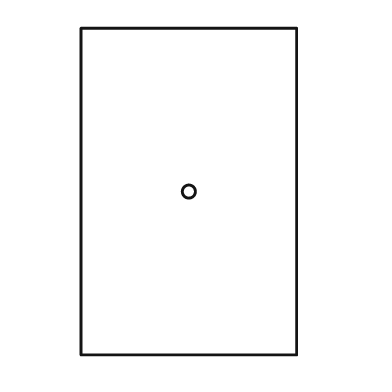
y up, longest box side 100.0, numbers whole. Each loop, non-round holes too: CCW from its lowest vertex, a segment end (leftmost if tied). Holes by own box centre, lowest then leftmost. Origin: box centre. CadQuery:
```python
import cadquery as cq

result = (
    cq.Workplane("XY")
    .moveTo(-33.0, -50.0)
    .lineTo(33.0, -50.0)
    .lineTo(33.0, 50.0)
    .lineTo(-33.0, 50.0)
    .close()
    .moveTo(0.0, 0.0)
    .circle(2.0)
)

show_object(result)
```